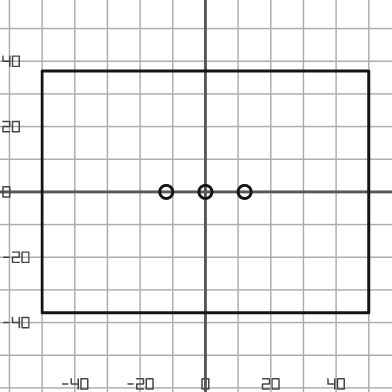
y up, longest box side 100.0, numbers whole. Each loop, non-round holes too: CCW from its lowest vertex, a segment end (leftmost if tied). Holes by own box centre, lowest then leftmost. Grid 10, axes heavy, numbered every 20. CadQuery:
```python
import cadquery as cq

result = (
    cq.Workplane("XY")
    .moveTo(-50.0, -37.0)
    .lineTo(50.0, -37.0)
    .lineTo(50.0, 37.0)
    .lineTo(-50.0, 37.0)
    .close()
    .moveTo(-12.0, 0.0)
    .circle(2.0)
    .moveTo(0.0, 0.0)
    .circle(2.0)
    .moveTo(12.0, 0.0)
    .circle(2.0)
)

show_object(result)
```